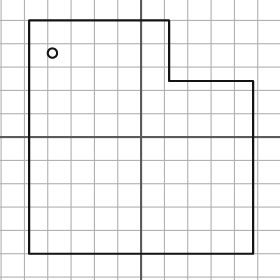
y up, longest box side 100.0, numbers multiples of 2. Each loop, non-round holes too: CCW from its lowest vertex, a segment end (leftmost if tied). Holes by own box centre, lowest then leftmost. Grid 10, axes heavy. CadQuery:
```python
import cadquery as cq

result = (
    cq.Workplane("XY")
    .moveTo(-48.0, -50.0)
    .lineTo(48.0, -50.0)
    .lineTo(48.0, 24.0)
    .lineTo(12.0, 24.0)
    .lineTo(12.0, 50.0)
    .lineTo(-48.0, 50.0)
    .close()
    .moveTo(-38.0, 36.0)
    .circle(2.0)
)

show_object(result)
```